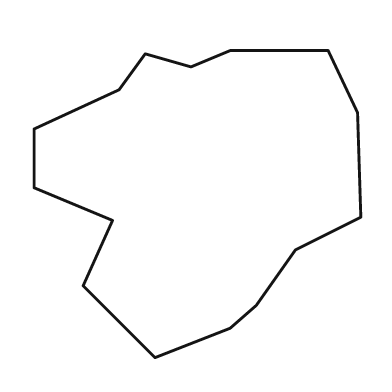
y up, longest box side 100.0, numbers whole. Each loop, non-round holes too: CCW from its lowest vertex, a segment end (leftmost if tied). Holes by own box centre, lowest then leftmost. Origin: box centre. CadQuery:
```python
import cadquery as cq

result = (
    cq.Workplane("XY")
    .moveTo(-13.0, -47.0)
    .lineTo(10.0, -38.0)
    .lineTo(18.0, -31.0)
    .lineTo(30.0, -14.0)
    .lineTo(50.0, -4.0)
    .lineTo(49.0, 28.0)
    .lineTo(40.0, 47.0)
    .lineTo(10.0, 47.0)
    .lineTo(-2.0, 42.0)
    .lineTo(-16.0, 46.0)
    .lineTo(-24.0, 35.0)
    .lineTo(-50.0, 23.0)
    .lineTo(-50.0, 5.0)
    .lineTo(-26.0, -5.0)
    .lineTo(-35.0, -25.0)
    .close()
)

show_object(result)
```